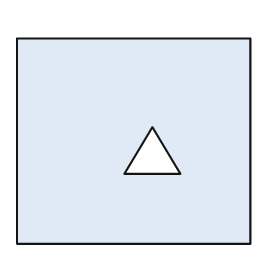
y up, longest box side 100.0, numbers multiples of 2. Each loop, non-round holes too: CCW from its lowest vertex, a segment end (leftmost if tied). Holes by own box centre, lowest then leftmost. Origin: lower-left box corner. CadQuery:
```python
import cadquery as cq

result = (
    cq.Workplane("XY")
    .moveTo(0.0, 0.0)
    .lineTo(100.0, 0.0)
    .lineTo(100.0, 88.0)
    .lineTo(0.0, 88.0)
    .close()
    .moveTo(46.0, 30.0)
    .lineTo(70.0, 30.0)
    .lineTo(58.0, 50.0)
    .close()
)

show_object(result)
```